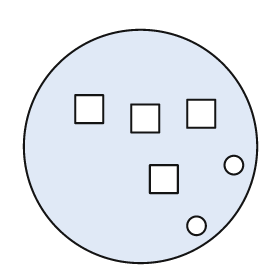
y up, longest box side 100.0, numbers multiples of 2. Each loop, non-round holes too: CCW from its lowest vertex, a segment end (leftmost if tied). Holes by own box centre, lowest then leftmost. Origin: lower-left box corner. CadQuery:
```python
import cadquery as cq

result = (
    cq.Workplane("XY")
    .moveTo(50.0, 50.0)
    .circle(50.0)
    .moveTo(74.0, 16.0)
    .circle(4.0)
    .moveTo(54.0, 30.0)
    .lineTo(66.0, 30.0)
    .lineTo(66.0, 42.0)
    .lineTo(54.0, 42.0)
    .close()
    .moveTo(90.0, 42.0)
    .circle(4.0)
    .moveTo(46.0, 56.0)
    .lineTo(58.0, 56.0)
    .lineTo(58.0, 68.0)
    .lineTo(46.0, 68.0)
    .close()
    .moveTo(70.0, 58.0)
    .lineTo(82.0, 58.0)
    .lineTo(82.0, 70.0)
    .lineTo(70.0, 70.0)
    .close()
    .moveTo(22.0, 60.0)
    .lineTo(34.0, 60.0)
    .lineTo(34.0, 72.0)
    .lineTo(22.0, 72.0)
    .close()
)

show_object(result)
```